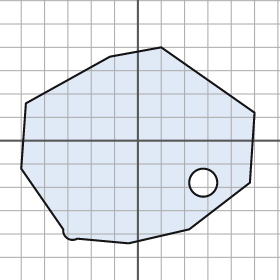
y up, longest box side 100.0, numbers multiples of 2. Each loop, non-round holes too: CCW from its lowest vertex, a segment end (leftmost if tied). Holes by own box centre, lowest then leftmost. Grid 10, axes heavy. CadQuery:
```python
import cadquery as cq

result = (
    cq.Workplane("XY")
    .moveTo(-4.0, -44.0)
    .lineTo(22.0, -38.0)
    .lineTo(48.0, -18.0)
    .lineTo(50.0, 12.0)
    .lineTo(10.0, 40.0)
    .lineTo(-12.0, 36.0)
    .lineTo(-48.0, 16.0)
    .lineTo(-50.0, -12.0)
    .lineTo(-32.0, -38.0)
    .threePointArc((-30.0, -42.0), (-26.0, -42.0))
    .close()
    .moveTo(28.0, -18.0)
    .circle(6.0)
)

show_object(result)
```